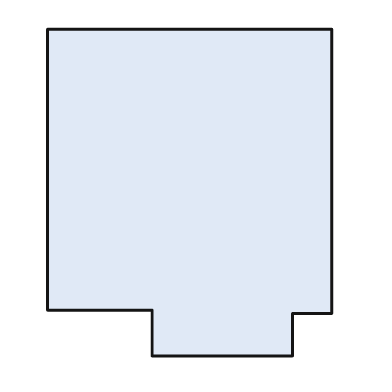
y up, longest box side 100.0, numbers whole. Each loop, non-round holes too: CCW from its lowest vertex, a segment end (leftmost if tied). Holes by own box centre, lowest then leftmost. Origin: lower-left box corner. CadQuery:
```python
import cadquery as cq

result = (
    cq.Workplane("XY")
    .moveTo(32.0, 0.0)
    .lineTo(75.0, 0.0)
    .lineTo(75.0, 13.0)
    .lineTo(87.0, 13.0)
    .lineTo(87.0, 100.0)
    .lineTo(0.0, 100.0)
    .lineTo(0.0, 14.0)
    .lineTo(32.0, 14.0)
    .close()
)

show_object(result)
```